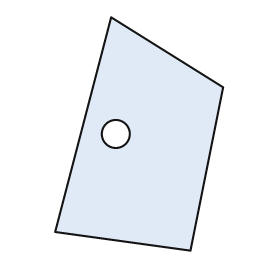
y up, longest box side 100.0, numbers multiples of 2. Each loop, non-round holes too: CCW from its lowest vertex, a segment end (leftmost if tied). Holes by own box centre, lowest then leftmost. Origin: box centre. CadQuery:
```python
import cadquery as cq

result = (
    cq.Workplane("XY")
    .moveTo(22.0, -50.0)
    .lineTo(36.0, 20.0)
    .lineTo(-12.0, 50.0)
    .lineTo(-36.0, -42.0)
    .close()
    .moveTo(-10.0, 0.0)
    .circle(6.0)
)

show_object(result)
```